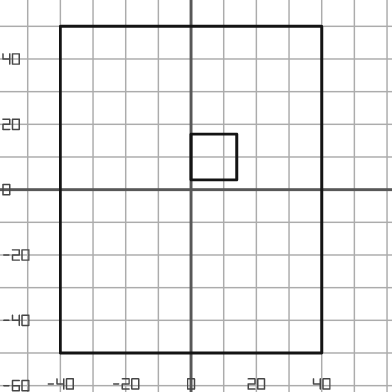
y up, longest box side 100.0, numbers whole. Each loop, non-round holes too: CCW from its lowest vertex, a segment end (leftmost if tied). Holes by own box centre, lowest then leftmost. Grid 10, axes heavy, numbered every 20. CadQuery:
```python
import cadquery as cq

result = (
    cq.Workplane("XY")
    .moveTo(-40.0, -50.0)
    .lineTo(40.0, -50.0)
    .lineTo(40.0, 50.0)
    .lineTo(-40.0, 50.0)
    .close()
    .moveTo(0.0, 3.0)
    .lineTo(14.0, 3.0)
    .lineTo(14.0, 17.0)
    .lineTo(0.0, 17.0)
    .close()
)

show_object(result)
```